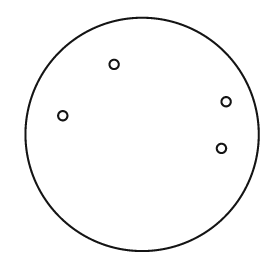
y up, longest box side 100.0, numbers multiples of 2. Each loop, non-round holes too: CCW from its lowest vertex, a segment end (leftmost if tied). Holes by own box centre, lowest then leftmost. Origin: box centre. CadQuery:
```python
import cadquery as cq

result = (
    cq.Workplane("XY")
    .moveTo(0.0, 0.0)
    .circle(50.0)
    .moveTo(34.0, -6.0)
    .circle(2.0)
    .moveTo(-34.0, 8.0)
    .circle(2.0)
    .moveTo(36.0, 14.0)
    .circle(2.0)
    .moveTo(-12.0, 30.0)
    .circle(2.0)
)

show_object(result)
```